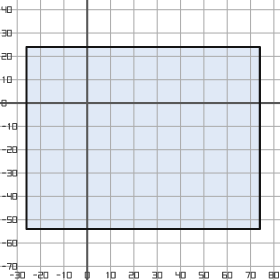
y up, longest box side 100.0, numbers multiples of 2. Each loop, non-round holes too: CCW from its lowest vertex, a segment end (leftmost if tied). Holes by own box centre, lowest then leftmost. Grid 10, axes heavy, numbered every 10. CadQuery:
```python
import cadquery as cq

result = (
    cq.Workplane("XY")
    .moveTo(-26.0, -54.0)
    .lineTo(74.0, -54.0)
    .lineTo(74.0, 24.0)
    .lineTo(-26.0, 24.0)
    .close()
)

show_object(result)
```